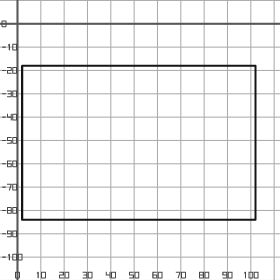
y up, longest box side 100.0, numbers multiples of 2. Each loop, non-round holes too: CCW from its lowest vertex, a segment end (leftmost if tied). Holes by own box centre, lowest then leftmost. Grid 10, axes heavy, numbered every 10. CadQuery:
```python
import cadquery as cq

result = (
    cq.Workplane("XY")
    .moveTo(2.0, -84.0)
    .lineTo(102.0, -84.0)
    .lineTo(102.0, -18.0)
    .lineTo(2.0, -18.0)
    .close()
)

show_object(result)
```